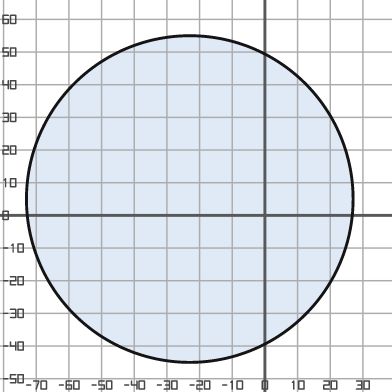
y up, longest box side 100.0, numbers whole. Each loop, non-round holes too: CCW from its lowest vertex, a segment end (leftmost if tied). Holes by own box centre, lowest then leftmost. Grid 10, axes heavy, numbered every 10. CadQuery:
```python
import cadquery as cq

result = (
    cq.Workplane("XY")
    .moveTo(-23.0, 5.0)
    .circle(50.0)
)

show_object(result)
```